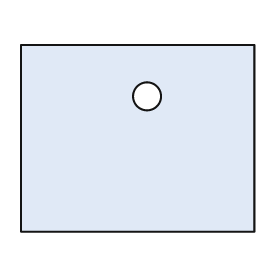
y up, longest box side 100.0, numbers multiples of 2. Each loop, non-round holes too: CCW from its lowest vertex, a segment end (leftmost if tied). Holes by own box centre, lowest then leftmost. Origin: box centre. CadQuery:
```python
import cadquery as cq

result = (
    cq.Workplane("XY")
    .moveTo(-50.0, -40.0)
    .lineTo(50.0, -40.0)
    .lineTo(50.0, 40.0)
    .lineTo(-50.0, 40.0)
    .close()
    .moveTo(4.0, 18.0)
    .circle(6.0)
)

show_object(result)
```